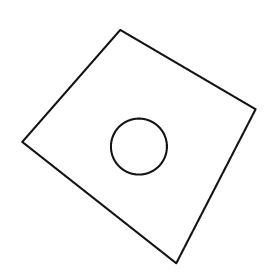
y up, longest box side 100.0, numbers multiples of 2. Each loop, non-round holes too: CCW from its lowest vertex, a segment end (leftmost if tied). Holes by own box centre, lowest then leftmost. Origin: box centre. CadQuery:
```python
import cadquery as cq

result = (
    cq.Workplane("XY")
    .moveTo(16.0, -50.0)
    .lineTo(50.0, 16.0)
    .lineTo(-8.0, 50.0)
    .lineTo(-50.0, 2.0)
    .close()
    .moveTo(0.0, 0.0)
    .circle(12.0)
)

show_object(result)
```